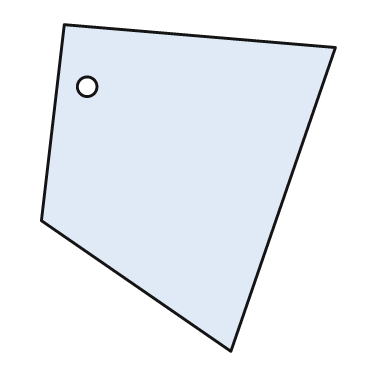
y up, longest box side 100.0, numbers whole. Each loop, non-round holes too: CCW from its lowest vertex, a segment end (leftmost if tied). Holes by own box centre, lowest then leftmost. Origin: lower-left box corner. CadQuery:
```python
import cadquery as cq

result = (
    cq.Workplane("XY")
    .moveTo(58.0, 0.0)
    .lineTo(90.0, 93.0)
    .lineTo(7.0, 100.0)
    .lineTo(0.0, 40.0)
    .close()
    .moveTo(14.0, 81.0)
    .circle(3.0)
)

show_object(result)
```